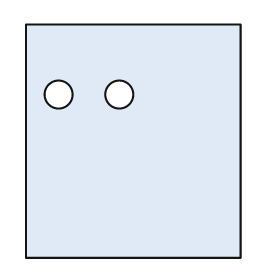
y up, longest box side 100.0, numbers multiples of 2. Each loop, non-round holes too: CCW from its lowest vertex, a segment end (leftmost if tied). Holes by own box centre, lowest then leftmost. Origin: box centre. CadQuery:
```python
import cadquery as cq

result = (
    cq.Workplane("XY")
    .moveTo(-46.0, -50.0)
    .lineTo(46.0, -50.0)
    .lineTo(46.0, 50.0)
    .lineTo(-46.0, 50.0)
    .close()
    .moveTo(-32.0, 20.0)
    .circle(6.0)
    .moveTo(-6.0, 20.0)
    .circle(6.0)
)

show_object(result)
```